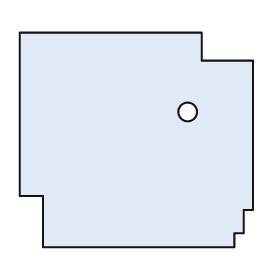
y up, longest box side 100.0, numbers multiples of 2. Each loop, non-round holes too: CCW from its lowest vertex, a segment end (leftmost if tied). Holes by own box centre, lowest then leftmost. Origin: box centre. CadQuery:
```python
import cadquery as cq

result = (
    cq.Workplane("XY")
    .moveTo(-40.0, -46.0)
    .lineTo(42.0, -46.0)
    .lineTo(42.0, -40.0)
    .lineTo(46.0, -40.0)
    .lineTo(46.0, -30.0)
    .lineTo(50.0, -30.0)
    .lineTo(50.0, 34.0)
    .lineTo(28.0, 34.0)
    .lineTo(28.0, 46.0)
    .lineTo(-50.0, 46.0)
    .lineTo(-50.0, -24.0)
    .lineTo(-40.0, -24.0)
    .close()
    .moveTo(22.0, 12.0)
    .circle(4.0)
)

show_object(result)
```